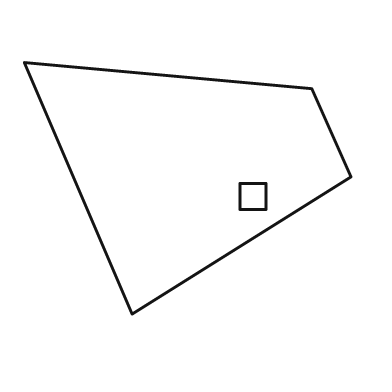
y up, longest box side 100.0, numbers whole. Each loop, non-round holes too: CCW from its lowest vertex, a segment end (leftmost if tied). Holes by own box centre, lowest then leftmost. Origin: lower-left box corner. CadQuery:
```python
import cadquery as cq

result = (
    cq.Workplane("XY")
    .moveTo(33.0, 0.0)
    .lineTo(100.0, 42.0)
    .lineTo(88.0, 69.0)
    .lineTo(0.0, 77.0)
    .close()
    .moveTo(66.0, 32.0)
    .lineTo(74.0, 32.0)
    .lineTo(74.0, 40.0)
    .lineTo(66.0, 40.0)
    .close()
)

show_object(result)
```